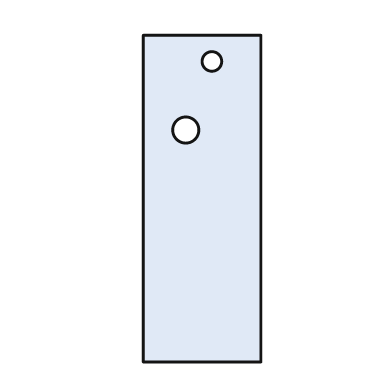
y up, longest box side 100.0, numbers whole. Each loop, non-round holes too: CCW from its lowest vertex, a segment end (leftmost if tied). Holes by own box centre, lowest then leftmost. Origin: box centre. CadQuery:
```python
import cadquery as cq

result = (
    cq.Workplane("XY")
    .moveTo(-18.0, -50.0)
    .lineTo(18.0, -50.0)
    .lineTo(18.0, 50.0)
    .lineTo(-18.0, 50.0)
    .close()
    .moveTo(-5.0, 21.0)
    .circle(4.0)
    .moveTo(3.0, 42.0)
    .circle(3.0)
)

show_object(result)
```